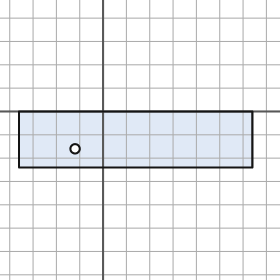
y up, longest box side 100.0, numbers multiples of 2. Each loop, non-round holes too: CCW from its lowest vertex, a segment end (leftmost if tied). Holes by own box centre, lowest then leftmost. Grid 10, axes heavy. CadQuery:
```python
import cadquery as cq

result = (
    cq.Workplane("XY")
    .moveTo(-36.0, -24.0)
    .lineTo(64.0, -24.0)
    .lineTo(64.0, 0.0)
    .lineTo(-36.0, 0.0)
    .close()
    .moveTo(-12.0, -16.0)
    .circle(2.0)
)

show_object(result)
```